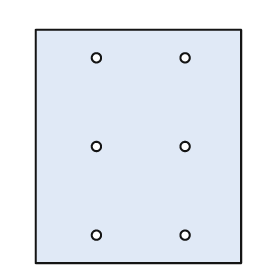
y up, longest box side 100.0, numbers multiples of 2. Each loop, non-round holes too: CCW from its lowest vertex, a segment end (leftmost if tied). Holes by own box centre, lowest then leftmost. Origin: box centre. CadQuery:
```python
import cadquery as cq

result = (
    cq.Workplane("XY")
    .moveTo(-44.0, -50.0)
    .lineTo(44.0, -50.0)
    .lineTo(44.0, 50.0)
    .lineTo(-44.0, 50.0)
    .close()
    .moveTo(-18.0, -38.0)
    .circle(2.0)
    .moveTo(20.0, -38.0)
    .circle(2.0)
    .moveTo(-18.0, 0.0)
    .circle(2.0)
    .moveTo(20.0, 0.0)
    .circle(2.0)
    .moveTo(-18.0, 38.0)
    .circle(2.0)
    .moveTo(20.0, 38.0)
    .circle(2.0)
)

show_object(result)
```